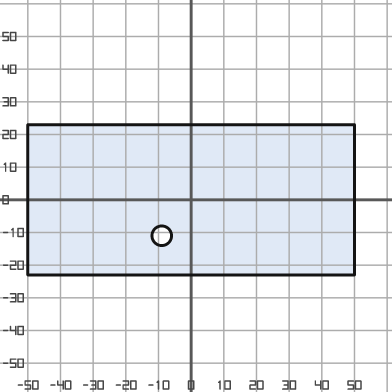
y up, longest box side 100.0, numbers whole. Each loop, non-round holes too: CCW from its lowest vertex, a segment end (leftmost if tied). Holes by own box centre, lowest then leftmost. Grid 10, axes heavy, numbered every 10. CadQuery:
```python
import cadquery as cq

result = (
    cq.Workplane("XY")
    .moveTo(-50.0, -23.0)
    .lineTo(50.0, -23.0)
    .lineTo(50.0, 23.0)
    .lineTo(-50.0, 23.0)
    .close()
    .moveTo(-9.0, -11.0)
    .circle(3.0)
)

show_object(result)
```